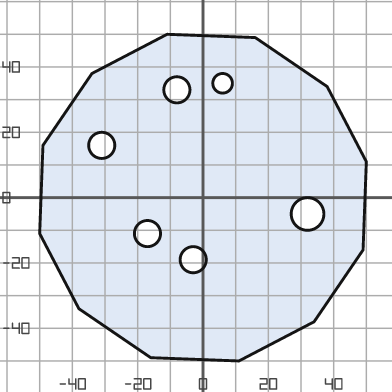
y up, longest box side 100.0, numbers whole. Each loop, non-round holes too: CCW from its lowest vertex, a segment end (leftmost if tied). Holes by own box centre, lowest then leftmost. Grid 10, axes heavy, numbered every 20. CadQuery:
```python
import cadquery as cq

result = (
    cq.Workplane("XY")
    .moveTo(11.0, -50.0)
    .lineTo(34.0, -38.0)
    .lineTo(49.0, -16.0)
    .lineTo(50.0, 11.0)
    .lineTo(38.0, 34.0)
    .lineTo(16.0, 49.0)
    .lineTo(-11.0, 50.0)
    .lineTo(-34.0, 38.0)
    .lineTo(-49.0, 16.0)
    .lineTo(-50.0, -11.0)
    .lineTo(-38.0, -34.0)
    .lineTo(-16.0, -49.0)
    .close()
    .moveTo(-3.0, -19.0)
    .circle(4.0)
    .moveTo(-17.0, -11.0)
    .circle(4.0)
    .moveTo(32.0, -5.0)
    .circle(5.0)
    .moveTo(-31.0, 16.0)
    .circle(4.0)
    .moveTo(-8.0, 33.0)
    .circle(4.0)
    .moveTo(6.0, 35.0)
    .circle(3.0)
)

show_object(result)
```